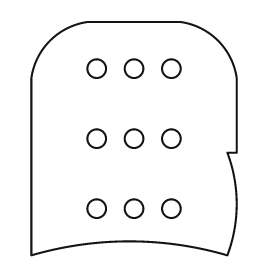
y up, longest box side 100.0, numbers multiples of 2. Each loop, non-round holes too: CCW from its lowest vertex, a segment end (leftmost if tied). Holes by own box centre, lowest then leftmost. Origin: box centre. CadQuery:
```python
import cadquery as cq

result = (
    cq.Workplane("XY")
    .moveTo(-44.0, -50.0)
    .threePointArc((-2.0, -44.0), (40.0, -50.0))
    .threePointArc((44.0, -28.0), (40.0, -6.0))
    .lineTo(44.0, -6.0)
    .lineTo(44.0, 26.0)
    .threePointArc((36.0, 42.0), (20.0, 50.0))
    .lineTo(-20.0, 50.0)
    .threePointArc((-36.0, 42.0), (-44.0, 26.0))
    .close()
    .moveTo(-16.0, -30.0)
    .circle(4.0)
    .moveTo(0.0, -30.0)
    .circle(4.0)
    .moveTo(16.0, -30.0)
    .circle(4.0)
    .moveTo(-16.0, 0.0)
    .circle(4.0)
    .moveTo(0.0, 0.0)
    .circle(4.0)
    .moveTo(16.0, 0.0)
    .circle(4.0)
    .moveTo(-16.0, 30.0)
    .circle(4.0)
    .moveTo(0.0, 30.0)
    .circle(4.0)
    .moveTo(16.0, 30.0)
    .circle(4.0)
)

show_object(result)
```